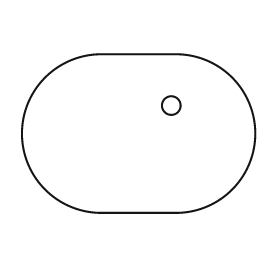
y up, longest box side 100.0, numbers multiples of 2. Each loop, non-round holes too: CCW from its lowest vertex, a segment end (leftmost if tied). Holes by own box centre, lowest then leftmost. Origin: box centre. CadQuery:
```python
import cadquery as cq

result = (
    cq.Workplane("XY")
    .moveTo(-16.0, -34.0)
    .lineTo(16.0, -34.0)
    .threePointArc((50.0, 0.0), (16.0, 34.0))
    .lineTo(-16.0, 34.0)
    .threePointArc((-50.0, 0.0), (-16.0, -34.0))
    .close()
    .moveTo(14.0, 12.0)
    .circle(4.0)
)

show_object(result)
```